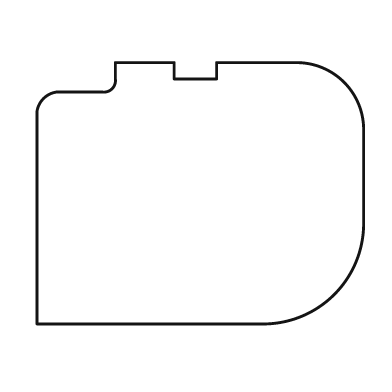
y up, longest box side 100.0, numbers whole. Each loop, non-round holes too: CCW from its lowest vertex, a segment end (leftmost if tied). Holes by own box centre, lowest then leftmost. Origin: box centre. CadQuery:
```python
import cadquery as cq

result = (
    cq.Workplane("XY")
    .moveTo(-50.0, -40.0)
    .lineTo(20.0, -40.0)
    .threePointArc((41.0, -31.0), (50.0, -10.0))
    .lineTo(50.0, 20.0)
    .threePointArc((44.0, 34.0), (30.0, 40.0))
    .lineTo(5.0, 40.0)
    .lineTo(5.0, 35.0)
    .lineTo(-8.0, 35.0)
    .lineTo(-8.0, 40.0)
    .lineTo(-26.0, 40.0)
    .lineTo(-26.0, 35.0)
    .threePointArc((-27.0, 32.0), (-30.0, 31.0))
    .lineTo(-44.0, 31.0)
    .threePointArc((-48.0, 29.0), (-50.0, 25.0))
    .close()
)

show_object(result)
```